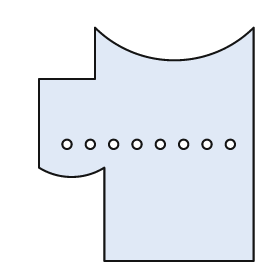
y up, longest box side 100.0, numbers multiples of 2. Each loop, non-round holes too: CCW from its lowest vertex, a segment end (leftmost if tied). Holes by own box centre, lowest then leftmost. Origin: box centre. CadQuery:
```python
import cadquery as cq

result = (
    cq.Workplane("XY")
    .moveTo(-18.0, -50.0)
    .lineTo(46.0, -50.0)
    .lineTo(46.0, 50.0)
    .threePointArc((12.0, 36.0), (-22.0, 50.0))
    .lineTo(-22.0, 28.0)
    .lineTo(-46.0, 28.0)
    .lineTo(-46.0, -10.0)
    .threePointArc((-32.0, -14.0), (-18.0, -10.0))
    .close()
    .moveTo(-34.0, 0.0)
    .circle(2.0)
    .moveTo(-24.0, 0.0)
    .circle(2.0)
    .moveTo(-14.0, 0.0)
    .circle(2.0)
    .moveTo(-4.0, 0.0)
    .circle(2.0)
    .moveTo(6.0, 0.0)
    .circle(2.0)
    .moveTo(16.0, 0.0)
    .circle(2.0)
    .moveTo(26.0, 0.0)
    .circle(2.0)
    .moveTo(36.0, 0.0)
    .circle(2.0)
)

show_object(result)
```